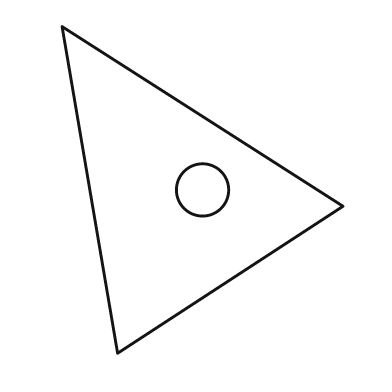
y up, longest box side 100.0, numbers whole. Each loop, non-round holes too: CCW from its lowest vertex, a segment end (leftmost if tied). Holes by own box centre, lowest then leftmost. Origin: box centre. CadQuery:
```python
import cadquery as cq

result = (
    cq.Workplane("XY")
    .moveTo(-26.0, -50.0)
    .lineTo(43.0, -5.0)
    .lineTo(-43.0, 50.0)
    .close()
    .moveTo(0.0, 0.0)
    .circle(8.0)
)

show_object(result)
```